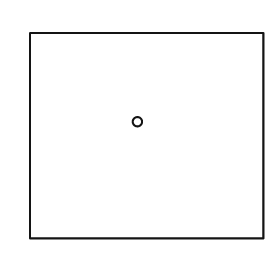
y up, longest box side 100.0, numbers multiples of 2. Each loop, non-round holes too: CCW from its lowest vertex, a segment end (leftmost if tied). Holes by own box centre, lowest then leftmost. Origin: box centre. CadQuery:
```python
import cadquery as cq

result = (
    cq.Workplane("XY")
    .moveTo(-50.0, -44.0)
    .lineTo(50.0, -44.0)
    .lineTo(50.0, 44.0)
    .lineTo(-50.0, 44.0)
    .close()
    .moveTo(-4.0, 6.0)
    .circle(2.0)
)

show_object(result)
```